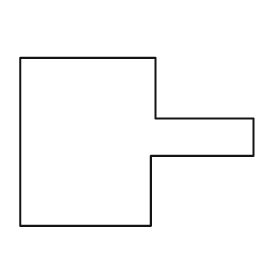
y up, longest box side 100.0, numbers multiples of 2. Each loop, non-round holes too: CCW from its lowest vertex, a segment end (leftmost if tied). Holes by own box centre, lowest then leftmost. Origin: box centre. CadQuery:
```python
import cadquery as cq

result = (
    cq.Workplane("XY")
    .moveTo(-50.0, -36.0)
    .lineTo(6.0, -36.0)
    .lineTo(6.0, -6.0)
    .lineTo(50.0, -6.0)
    .lineTo(50.0, 10.0)
    .lineTo(8.0, 10.0)
    .lineTo(8.0, 36.0)
    .lineTo(-50.0, 36.0)
    .close()
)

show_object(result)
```